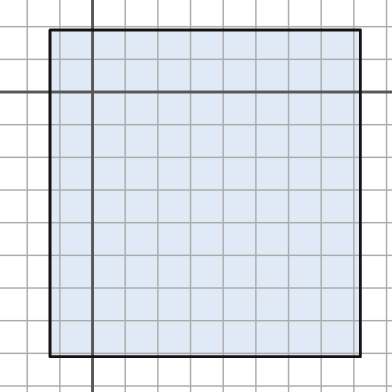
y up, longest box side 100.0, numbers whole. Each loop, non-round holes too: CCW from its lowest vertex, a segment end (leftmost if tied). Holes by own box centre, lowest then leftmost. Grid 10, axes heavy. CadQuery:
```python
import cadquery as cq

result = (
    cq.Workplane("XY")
    .moveTo(-13.0, -81.0)
    .lineTo(82.0, -81.0)
    .lineTo(82.0, 19.0)
    .lineTo(-13.0, 19.0)
    .close()
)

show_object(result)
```